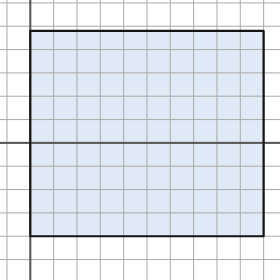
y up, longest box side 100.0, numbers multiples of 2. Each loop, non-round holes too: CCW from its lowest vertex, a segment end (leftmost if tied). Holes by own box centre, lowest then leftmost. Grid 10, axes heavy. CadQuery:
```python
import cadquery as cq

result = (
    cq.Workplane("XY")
    .moveTo(0.0, -40.0)
    .lineTo(100.0, -40.0)
    .lineTo(100.0, 48.0)
    .lineTo(0.0, 48.0)
    .close()
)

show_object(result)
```